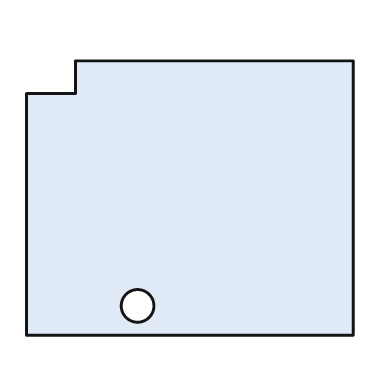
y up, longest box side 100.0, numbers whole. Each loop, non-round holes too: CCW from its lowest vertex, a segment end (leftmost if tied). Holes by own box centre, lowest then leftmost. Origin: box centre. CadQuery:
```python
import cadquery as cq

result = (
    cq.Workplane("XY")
    .moveTo(-50.0, -42.0)
    .lineTo(50.0, -42.0)
    .lineTo(50.0, 42.0)
    .lineTo(-35.0, 42.0)
    .lineTo(-35.0, 32.0)
    .lineTo(-50.0, 32.0)
    .close()
    .moveTo(-16.0, -33.0)
    .circle(5.0)
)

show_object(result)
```